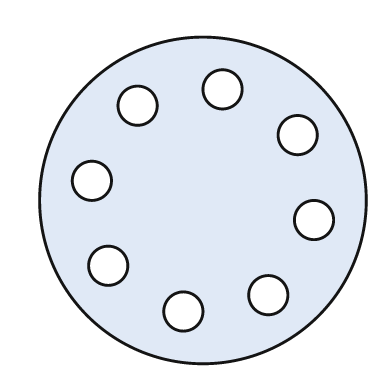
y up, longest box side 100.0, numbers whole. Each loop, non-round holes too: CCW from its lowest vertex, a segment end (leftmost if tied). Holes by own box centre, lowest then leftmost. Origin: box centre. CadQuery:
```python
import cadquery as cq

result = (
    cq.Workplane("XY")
    .moveTo(0.0, 0.0)
    .circle(50.0)
    .moveTo(-6.0, -34.0)
    .circle(6.0)
    .moveTo(20.0, -29.0)
    .circle(6.0)
    .moveTo(-29.0, -20.0)
    .circle(6.0)
    .moveTo(34.0, -6.0)
    .circle(6.0)
    .moveTo(-34.0, 6.0)
    .circle(6.0)
    .moveTo(29.0, 20.0)
    .circle(6.0)
    .moveTo(-20.0, 29.0)
    .circle(6.0)
    .moveTo(6.0, 34.0)
    .circle(6.0)
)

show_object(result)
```